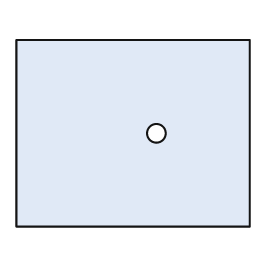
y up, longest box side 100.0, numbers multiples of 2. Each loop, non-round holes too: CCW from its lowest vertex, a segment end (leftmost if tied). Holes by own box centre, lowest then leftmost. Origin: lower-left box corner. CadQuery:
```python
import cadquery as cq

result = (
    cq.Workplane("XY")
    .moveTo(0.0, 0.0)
    .lineTo(100.0, 0.0)
    .lineTo(100.0, 80.0)
    .lineTo(0.0, 80.0)
    .close()
    .moveTo(60.0, 40.0)
    .circle(4.0)
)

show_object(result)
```